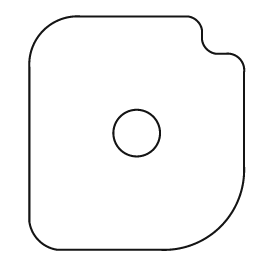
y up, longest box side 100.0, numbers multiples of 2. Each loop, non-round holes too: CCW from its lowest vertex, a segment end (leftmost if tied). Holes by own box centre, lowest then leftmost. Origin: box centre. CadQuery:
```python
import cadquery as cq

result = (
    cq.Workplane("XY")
    .moveTo(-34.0, -50.0)
    .lineTo(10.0, -50.0)
    .threePointArc((36.0, -40.0), (46.0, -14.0))
    .lineTo(46.0, 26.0)
    .threePointArc((44.0, 32.0), (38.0, 34.0))
    .lineTo(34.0, 34.0)
    .threePointArc((30.0, 36.0), (28.0, 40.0))
    .lineTo(28.0, 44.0)
    .threePointArc((26.0, 48.0), (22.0, 50.0))
    .lineTo(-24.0, 50.0)
    .threePointArc((-40.0, 44.0), (-46.0, 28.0))
    .lineTo(-46.0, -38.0)
    .threePointArc((-42.0, -46.0), (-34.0, -50.0))
    .close()
    .moveTo(0.0, 0.0)
    .circle(10.0)
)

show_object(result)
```